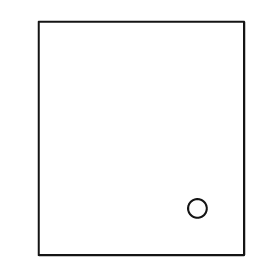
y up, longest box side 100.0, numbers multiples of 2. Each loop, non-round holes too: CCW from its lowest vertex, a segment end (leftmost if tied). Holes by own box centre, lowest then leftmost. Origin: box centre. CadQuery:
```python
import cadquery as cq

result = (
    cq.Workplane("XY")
    .moveTo(-44.0, -50.0)
    .lineTo(44.0, -50.0)
    .lineTo(44.0, 50.0)
    .lineTo(-44.0, 50.0)
    .close()
    .moveTo(24.0, -30.0)
    .circle(4.0)
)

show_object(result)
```